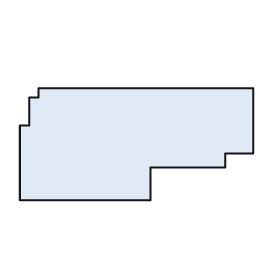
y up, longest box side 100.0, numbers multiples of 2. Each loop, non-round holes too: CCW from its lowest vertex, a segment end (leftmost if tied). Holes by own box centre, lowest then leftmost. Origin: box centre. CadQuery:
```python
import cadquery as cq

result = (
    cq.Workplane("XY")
    .moveTo(-50.0, -24.0)
    .lineTo(6.0, -24.0)
    .lineTo(6.0, -10.0)
    .lineTo(38.0, -10.0)
    .lineTo(38.0, -4.0)
    .lineTo(50.0, -4.0)
    .lineTo(50.0, 24.0)
    .lineTo(-42.0, 24.0)
    .lineTo(-42.0, 20.0)
    .lineTo(-46.0, 20.0)
    .lineTo(-46.0, 8.0)
    .lineTo(-50.0, 8.0)
    .close()
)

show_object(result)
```